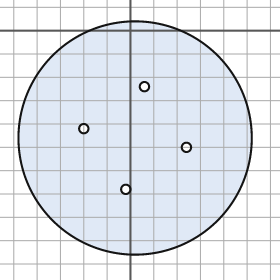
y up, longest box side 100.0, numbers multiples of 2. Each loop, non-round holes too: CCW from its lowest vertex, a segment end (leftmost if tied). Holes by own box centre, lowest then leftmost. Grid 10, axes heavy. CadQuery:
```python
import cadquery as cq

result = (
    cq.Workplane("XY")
    .moveTo(2.0, -46.0)
    .circle(50.0)
    .moveTo(-2.0, -68.0)
    .circle(2.0)
    .moveTo(24.0, -50.0)
    .circle(2.0)
    .moveTo(-20.0, -42.0)
    .circle(2.0)
    .moveTo(6.0, -24.0)
    .circle(2.0)
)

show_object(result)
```